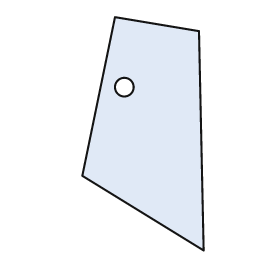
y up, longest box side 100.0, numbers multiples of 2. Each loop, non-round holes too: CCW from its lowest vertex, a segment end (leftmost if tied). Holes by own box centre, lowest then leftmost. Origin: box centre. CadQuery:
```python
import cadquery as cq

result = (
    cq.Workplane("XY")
    .moveTo(26.0, -50.0)
    .lineTo(24.0, 44.0)
    .lineTo(-12.0, 50.0)
    .lineTo(-26.0, -18.0)
    .close()
    .moveTo(-8.0, 20.0)
    .circle(4.0)
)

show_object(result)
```